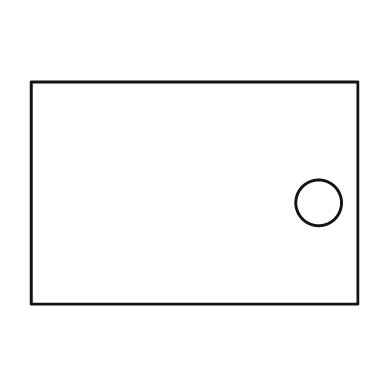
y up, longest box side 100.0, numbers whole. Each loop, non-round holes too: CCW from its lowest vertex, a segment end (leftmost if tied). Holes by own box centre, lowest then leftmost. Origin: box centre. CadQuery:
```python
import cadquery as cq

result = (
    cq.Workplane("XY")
    .moveTo(-50.0, -34.0)
    .lineTo(50.0, -34.0)
    .lineTo(50.0, 34.0)
    .lineTo(-50.0, 34.0)
    .close()
    .moveTo(38.0, -3.0)
    .circle(7.0)
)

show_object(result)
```